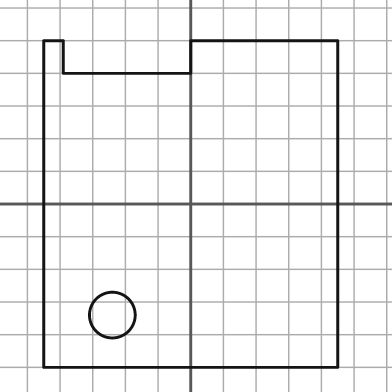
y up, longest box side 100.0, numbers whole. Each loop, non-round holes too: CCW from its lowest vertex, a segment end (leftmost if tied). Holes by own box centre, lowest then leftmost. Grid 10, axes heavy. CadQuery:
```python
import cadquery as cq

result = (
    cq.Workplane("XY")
    .moveTo(-45.0, -50.0)
    .lineTo(45.0, -50.0)
    .lineTo(45.0, 50.0)
    .lineTo(0.0, 50.0)
    .lineTo(0.0, 40.0)
    .lineTo(-39.0, 40.0)
    .lineTo(-39.0, 50.0)
    .lineTo(-45.0, 50.0)
    .close()
    .moveTo(-24.0, -34.0)
    .circle(7.0)
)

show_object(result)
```